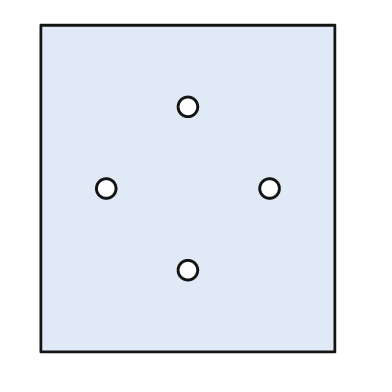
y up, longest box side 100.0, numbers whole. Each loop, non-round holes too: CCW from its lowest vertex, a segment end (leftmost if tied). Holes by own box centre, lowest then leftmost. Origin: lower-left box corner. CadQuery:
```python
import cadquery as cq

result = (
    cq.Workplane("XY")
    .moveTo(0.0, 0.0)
    .lineTo(90.0, 0.0)
    .lineTo(90.0, 100.0)
    .lineTo(0.0, 100.0)
    .close()
    .moveTo(45.0, 25.0)
    .circle(3.0)
    .moveTo(20.0, 50.0)
    .circle(3.0)
    .moveTo(70.0, 50.0)
    .circle(3.0)
    .moveTo(45.0, 75.0)
    .circle(3.0)
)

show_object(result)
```